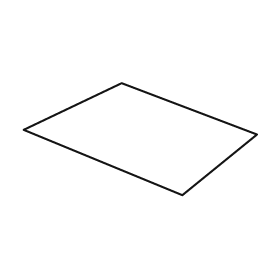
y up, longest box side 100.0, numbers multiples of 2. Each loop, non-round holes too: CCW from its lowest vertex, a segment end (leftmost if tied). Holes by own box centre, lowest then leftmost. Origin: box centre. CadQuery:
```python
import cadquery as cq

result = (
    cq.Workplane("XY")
    .moveTo(18.0, -24.0)
    .lineTo(50.0, 2.0)
    .lineTo(-8.0, 24.0)
    .lineTo(-50.0, 4.0)
    .close()
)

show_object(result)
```